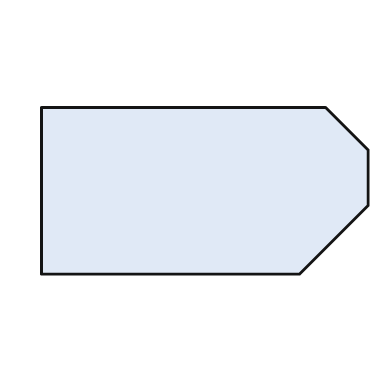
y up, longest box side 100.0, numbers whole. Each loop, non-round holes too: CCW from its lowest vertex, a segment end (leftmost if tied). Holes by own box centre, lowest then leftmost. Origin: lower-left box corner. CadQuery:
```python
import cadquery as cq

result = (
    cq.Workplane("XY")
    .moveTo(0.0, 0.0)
    .lineTo(79.0, 0.0)
    .lineTo(100.0, 21.0)
    .lineTo(100.0, 38.0)
    .lineTo(87.0, 51.0)
    .lineTo(0.0, 51.0)
    .close()
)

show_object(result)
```